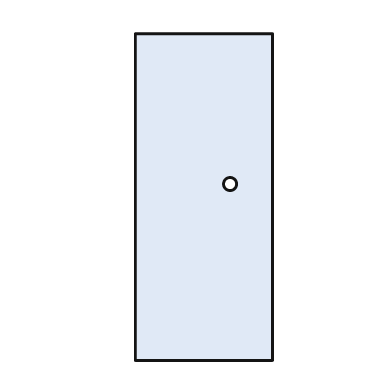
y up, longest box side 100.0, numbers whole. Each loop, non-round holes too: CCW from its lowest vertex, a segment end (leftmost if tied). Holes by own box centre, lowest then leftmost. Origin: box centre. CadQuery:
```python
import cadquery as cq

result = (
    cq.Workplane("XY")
    .moveTo(-21.0, -50.0)
    .lineTo(21.0, -50.0)
    .lineTo(21.0, 50.0)
    .lineTo(-21.0, 50.0)
    .close()
    .moveTo(8.0, 4.0)
    .circle(2.0)
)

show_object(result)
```